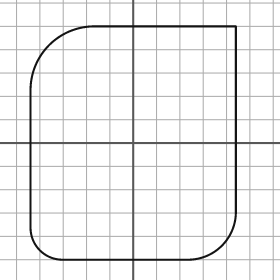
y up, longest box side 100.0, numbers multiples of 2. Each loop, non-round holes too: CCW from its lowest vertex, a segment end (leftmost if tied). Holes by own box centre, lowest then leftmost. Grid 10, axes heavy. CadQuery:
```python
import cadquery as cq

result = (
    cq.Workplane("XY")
    .moveTo(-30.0, -50.0)
    .lineTo(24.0, -50.0)
    .threePointArc((38.0, -44.0), (44.0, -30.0))
    .lineTo(44.0, 50.0)
    .lineTo(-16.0, 50.0)
    .threePointArc((-36.0, 42.0), (-44.0, 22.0))
    .lineTo(-44.0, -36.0)
    .threePointArc((-40.0, -46.0), (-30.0, -50.0))
    .close()
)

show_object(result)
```